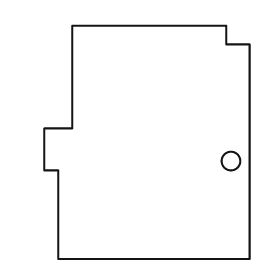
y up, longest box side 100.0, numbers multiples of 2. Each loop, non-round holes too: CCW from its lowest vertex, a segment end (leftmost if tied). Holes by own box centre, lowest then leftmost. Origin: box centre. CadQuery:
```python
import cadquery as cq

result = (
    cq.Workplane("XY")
    .moveTo(-38.0, -50.0)
    .lineTo(44.0, -50.0)
    .lineTo(44.0, 42.0)
    .lineTo(34.0, 42.0)
    .lineTo(34.0, 50.0)
    .lineTo(-32.0, 50.0)
    .lineTo(-32.0, 6.0)
    .lineTo(-44.0, 6.0)
    .lineTo(-44.0, -12.0)
    .lineTo(-38.0, -12.0)
    .close()
    .moveTo(36.0, -8.0)
    .circle(4.0)
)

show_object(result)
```